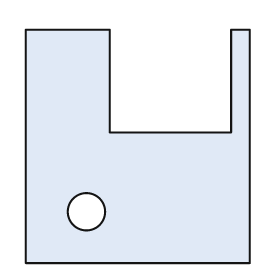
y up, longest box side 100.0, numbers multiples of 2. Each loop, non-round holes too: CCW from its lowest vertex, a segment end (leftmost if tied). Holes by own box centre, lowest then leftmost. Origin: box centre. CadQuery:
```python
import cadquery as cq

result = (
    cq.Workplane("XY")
    .moveTo(-48.0, -50.0)
    .lineTo(48.0, -50.0)
    .lineTo(48.0, 50.0)
    .lineTo(40.0, 50.0)
    .lineTo(40.0, 6.0)
    .lineTo(-12.0, 6.0)
    .lineTo(-12.0, 50.0)
    .lineTo(-48.0, 50.0)
    .close()
    .moveTo(-22.0, -28.0)
    .circle(8.0)
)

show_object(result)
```